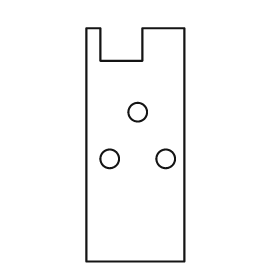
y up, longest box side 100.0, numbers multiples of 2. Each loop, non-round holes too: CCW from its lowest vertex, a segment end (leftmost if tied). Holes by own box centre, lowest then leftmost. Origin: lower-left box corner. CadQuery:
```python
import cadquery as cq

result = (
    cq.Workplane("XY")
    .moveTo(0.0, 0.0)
    .lineTo(42.0, 0.0)
    .lineTo(42.0, 100.0)
    .lineTo(24.0, 100.0)
    .lineTo(24.0, 86.0)
    .lineTo(6.0, 86.0)
    .lineTo(6.0, 100.0)
    .lineTo(0.0, 100.0)
    .close()
    .moveTo(10.0, 44.0)
    .circle(4.0)
    .moveTo(34.0, 44.0)
    .circle(4.0)
    .moveTo(22.0, 64.0)
    .circle(4.0)
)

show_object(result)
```